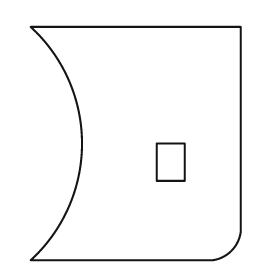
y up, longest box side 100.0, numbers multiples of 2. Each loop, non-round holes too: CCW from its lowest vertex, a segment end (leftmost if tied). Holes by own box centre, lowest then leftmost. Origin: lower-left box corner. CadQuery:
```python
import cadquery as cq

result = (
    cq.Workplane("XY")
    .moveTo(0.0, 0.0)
    .lineTo(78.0, 0.0)
    .threePointArc((86.0, 4.0), (90.0, 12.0))
    .lineTo(90.0, 100.0)
    .lineTo(0.0, 100.0)
    .threePointArc((22.0, 50.0), (0.0, 0.0))
    .close()
    .moveTo(54.0, 34.0)
    .lineTo(66.0, 34.0)
    .lineTo(66.0, 50.0)
    .lineTo(54.0, 50.0)
    .close()
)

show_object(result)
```